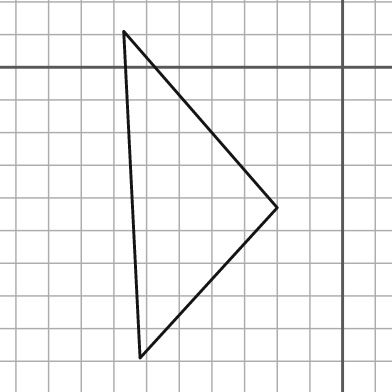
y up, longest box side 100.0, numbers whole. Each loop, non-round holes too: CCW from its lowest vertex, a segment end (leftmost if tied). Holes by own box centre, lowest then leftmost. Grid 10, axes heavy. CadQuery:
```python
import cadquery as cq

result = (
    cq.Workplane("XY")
    .moveTo(-62.0, -89.0)
    .lineTo(-20.0, -43.0)
    .lineTo(-67.0, 11.0)
    .close()
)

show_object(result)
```